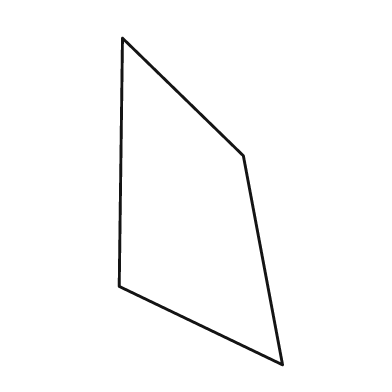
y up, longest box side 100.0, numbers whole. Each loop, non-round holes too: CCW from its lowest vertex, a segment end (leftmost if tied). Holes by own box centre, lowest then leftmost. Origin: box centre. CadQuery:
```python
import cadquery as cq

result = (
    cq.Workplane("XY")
    .moveTo(25.0, -50.0)
    .lineTo(13.0, 14.0)
    .lineTo(-24.0, 50.0)
    .lineTo(-25.0, -26.0)
    .close()
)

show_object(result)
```